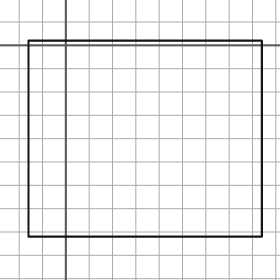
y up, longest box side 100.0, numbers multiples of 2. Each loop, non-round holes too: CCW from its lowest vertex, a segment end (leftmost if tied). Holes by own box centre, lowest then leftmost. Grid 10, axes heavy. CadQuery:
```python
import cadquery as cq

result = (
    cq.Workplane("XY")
    .moveTo(-16.0, -82.0)
    .lineTo(84.0, -82.0)
    .lineTo(84.0, 2.0)
    .lineTo(-16.0, 2.0)
    .close()
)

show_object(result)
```